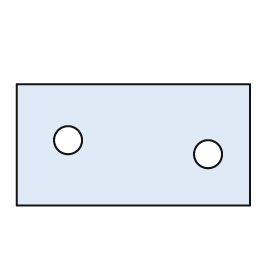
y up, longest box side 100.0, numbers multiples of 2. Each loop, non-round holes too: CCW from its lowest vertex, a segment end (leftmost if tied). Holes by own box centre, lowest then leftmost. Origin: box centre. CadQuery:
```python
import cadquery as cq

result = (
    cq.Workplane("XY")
    .moveTo(-50.0, -26.0)
    .lineTo(50.0, -26.0)
    .lineTo(50.0, 26.0)
    .lineTo(-50.0, 26.0)
    .close()
    .moveTo(32.0, -4.0)
    .circle(6.0)
    .moveTo(-28.0, 2.0)
    .circle(6.0)
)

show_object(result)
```